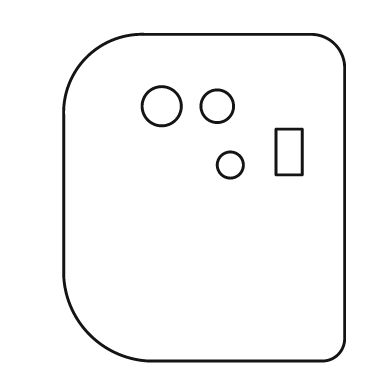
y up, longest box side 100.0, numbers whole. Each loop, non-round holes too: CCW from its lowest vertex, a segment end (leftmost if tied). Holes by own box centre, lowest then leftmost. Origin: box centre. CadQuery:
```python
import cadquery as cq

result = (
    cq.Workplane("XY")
    .moveTo(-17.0, -50.0)
    .lineTo(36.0, -50.0)
    .threePointArc((41.0, -48.0), (43.0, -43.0))
    .lineTo(43.0, 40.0)
    .threePointArc((40.0, 47.0), (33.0, 50.0))
    .lineTo(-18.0, 50.0)
    .threePointArc((-36.0, 43.0), (-43.0, 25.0))
    .lineTo(-43.0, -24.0)
    .threePointArc((-35.0, -42.0), (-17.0, -50.0))
    .close()
    .moveTo(8.0, 10.0)
    .circle(4.0)
    .moveTo(22.0, 7.0)
    .lineTo(30.0, 7.0)
    .lineTo(30.0, 21.0)
    .lineTo(22.0, 21.0)
    .close()
    .moveTo(-13.0, 28.0)
    .circle(6.0)
    .moveTo(4.0, 28.0)
    .circle(5.0)
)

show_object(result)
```